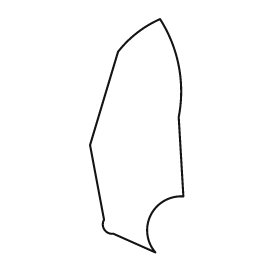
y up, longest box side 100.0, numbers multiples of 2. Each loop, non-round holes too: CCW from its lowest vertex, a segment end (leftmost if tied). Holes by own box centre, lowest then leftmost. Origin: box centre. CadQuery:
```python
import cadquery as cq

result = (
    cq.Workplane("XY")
    .moveTo(8.0, -50.0)
    .threePointArc((6.0, -34.0), (20.0, -26.0))
    .lineTo(18.0, 8.0)
    .threePointArc((18.0, 30.0), (10.0, 50.0))
    .threePointArc((0.0, 44.0), (-8.0, 36.0))
    .lineTo(-20.0, -4.0)
    .lineTo(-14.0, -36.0)
    .threePointArc((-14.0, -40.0), (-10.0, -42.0))
    .close()
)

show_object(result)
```